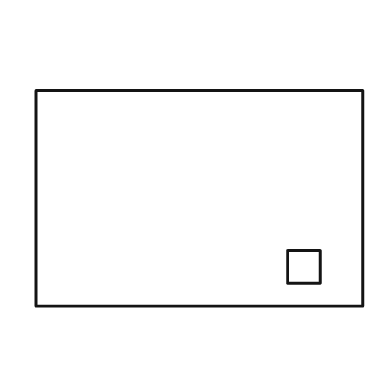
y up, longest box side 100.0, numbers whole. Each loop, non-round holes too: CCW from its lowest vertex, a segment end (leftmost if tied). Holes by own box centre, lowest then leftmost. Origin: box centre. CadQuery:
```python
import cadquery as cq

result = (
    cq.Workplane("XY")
    .moveTo(-50.0, -33.0)
    .lineTo(50.0, -33.0)
    .lineTo(50.0, 33.0)
    .lineTo(-50.0, 33.0)
    .close()
    .moveTo(27.0, -26.0)
    .lineTo(37.0, -26.0)
    .lineTo(37.0, -16.0)
    .lineTo(27.0, -16.0)
    .close()
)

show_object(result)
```